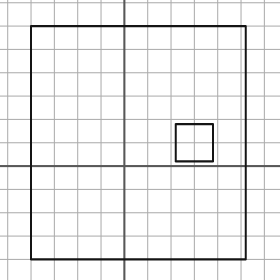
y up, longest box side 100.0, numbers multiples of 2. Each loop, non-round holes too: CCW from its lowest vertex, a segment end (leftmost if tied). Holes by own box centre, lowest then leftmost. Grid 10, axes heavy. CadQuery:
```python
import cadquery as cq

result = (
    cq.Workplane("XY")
    .moveTo(-40.0, -40.0)
    .lineTo(52.0, -40.0)
    .lineTo(52.0, 60.0)
    .lineTo(-40.0, 60.0)
    .close()
    .moveTo(22.0, 2.0)
    .lineTo(38.0, 2.0)
    .lineTo(38.0, 18.0)
    .lineTo(22.0, 18.0)
    .close()
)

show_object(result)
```